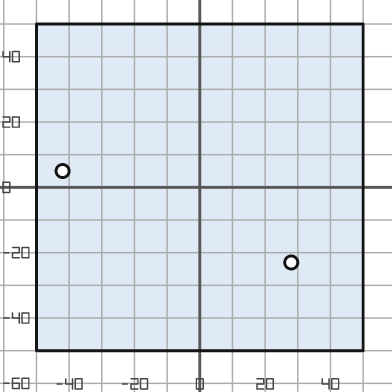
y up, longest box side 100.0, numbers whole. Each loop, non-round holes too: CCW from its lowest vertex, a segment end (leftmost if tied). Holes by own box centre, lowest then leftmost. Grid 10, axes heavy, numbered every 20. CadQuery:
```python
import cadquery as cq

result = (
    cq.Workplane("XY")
    .moveTo(-50.0, -50.0)
    .lineTo(50.0, -50.0)
    .lineTo(50.0, 50.0)
    .lineTo(-50.0, 50.0)
    .close()
    .moveTo(28.0, -23.0)
    .circle(2.0)
    .moveTo(-42.0, 5.0)
    .circle(2.0)
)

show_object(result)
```